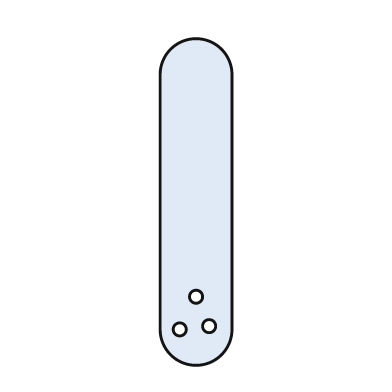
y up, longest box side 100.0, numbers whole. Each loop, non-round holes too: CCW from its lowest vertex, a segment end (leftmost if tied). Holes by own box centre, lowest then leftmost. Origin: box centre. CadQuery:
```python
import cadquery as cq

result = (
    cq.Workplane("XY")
    .moveTo(-11.0, -39.0)
    .threePointArc((0.0, -50.0), (11.0, -39.0))
    .lineTo(11.0, 39.0)
    .threePointArc((0.0, 50.0), (-11.0, 39.0))
    .close()
    .moveTo(-5.0, -39.0)
    .circle(2.0)
    .moveTo(4.0, -38.0)
    .circle(2.0)
    .moveTo(0.0, -29.0)
    .circle(2.0)
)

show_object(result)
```